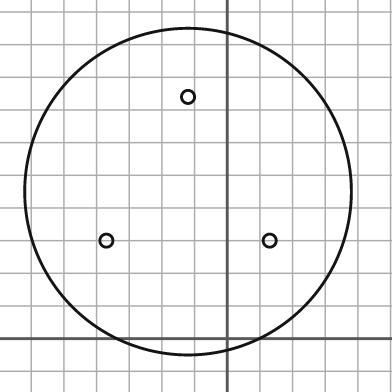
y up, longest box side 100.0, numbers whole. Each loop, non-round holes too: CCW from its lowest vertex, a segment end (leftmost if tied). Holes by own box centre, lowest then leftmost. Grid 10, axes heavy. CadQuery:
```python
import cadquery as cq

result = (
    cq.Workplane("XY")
    .moveTo(-12.0, 45.0)
    .circle(50.0)
    .moveTo(-37.0, 30.0)
    .circle(2.0)
    .moveTo(13.0, 30.0)
    .circle(2.0)
    .moveTo(-12.0, 74.0)
    .circle(2.0)
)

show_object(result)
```